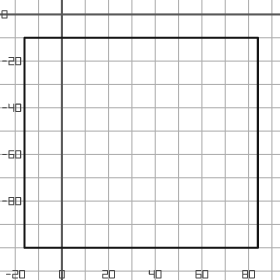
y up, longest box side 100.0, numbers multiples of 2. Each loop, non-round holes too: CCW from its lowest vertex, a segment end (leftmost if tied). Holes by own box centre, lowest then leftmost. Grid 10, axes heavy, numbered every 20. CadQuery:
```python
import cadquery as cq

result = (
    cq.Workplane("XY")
    .moveTo(-16.0, -100.0)
    .lineTo(84.0, -100.0)
    .lineTo(84.0, -10.0)
    .lineTo(-16.0, -10.0)
    .close()
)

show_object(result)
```